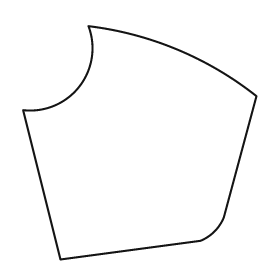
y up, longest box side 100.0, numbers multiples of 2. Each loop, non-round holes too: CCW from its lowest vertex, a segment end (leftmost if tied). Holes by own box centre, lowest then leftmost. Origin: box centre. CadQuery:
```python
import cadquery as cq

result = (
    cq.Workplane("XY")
    .moveTo(-34.0, -50.0)
    .lineTo(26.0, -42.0)
    .threePointArc((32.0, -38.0), (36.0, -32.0))
    .lineTo(50.0, 20.0)
    .threePointArc((16.0, 40.0), (-22.0, 50.0))
    .threePointArc((-26.0, 24.0), (-50.0, 14.0))
    .close()
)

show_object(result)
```